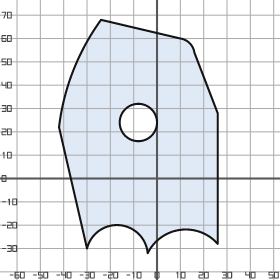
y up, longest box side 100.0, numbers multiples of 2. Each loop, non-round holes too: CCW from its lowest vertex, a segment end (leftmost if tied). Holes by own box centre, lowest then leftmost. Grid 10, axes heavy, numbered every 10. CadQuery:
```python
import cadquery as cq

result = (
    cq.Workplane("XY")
    .moveTo(-4.0, -32.0)
    .threePointArc((10.0, -22.0), (26.0, -28.0))
    .lineTo(26.0, 28.0)
    .lineTo(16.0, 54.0)
    .threePointArc((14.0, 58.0), (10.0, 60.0))
    .lineTo(-24.0, 68.0)
    .threePointArc((-36.0, 46.0), (-42.0, 22.0))
    .lineTo(-30.0, -30.0)
    .threePointArc((-16.0, -20.0), (-4.0, -32.0))
    .close()
    .moveTo(-8.0, 24.0)
    .circle(8.0)
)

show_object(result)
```